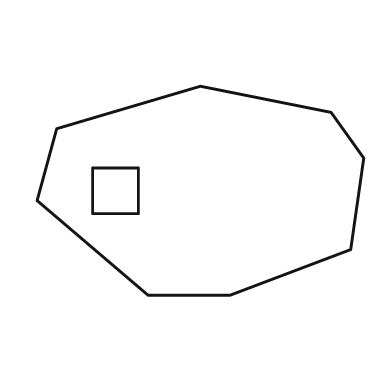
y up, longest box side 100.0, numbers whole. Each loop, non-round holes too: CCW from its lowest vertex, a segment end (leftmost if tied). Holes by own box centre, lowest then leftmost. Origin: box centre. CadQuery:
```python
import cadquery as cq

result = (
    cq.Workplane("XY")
    .moveTo(-16.0, -32.0)
    .lineTo(9.0, -32.0)
    .lineTo(46.0, -18.0)
    .lineTo(50.0, 10.0)
    .lineTo(40.0, 24.0)
    .lineTo(0.0, 32.0)
    .lineTo(-44.0, 19.0)
    .lineTo(-50.0, -3.0)
    .close()
    .moveTo(-33.0, -7.0)
    .lineTo(-19.0, -7.0)
    .lineTo(-19.0, 7.0)
    .lineTo(-33.0, 7.0)
    .close()
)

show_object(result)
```